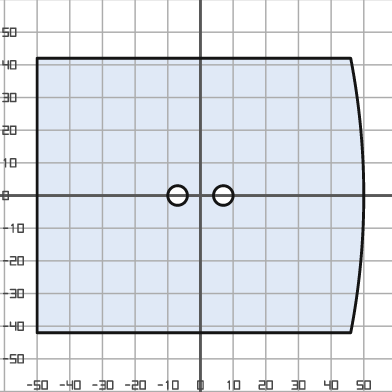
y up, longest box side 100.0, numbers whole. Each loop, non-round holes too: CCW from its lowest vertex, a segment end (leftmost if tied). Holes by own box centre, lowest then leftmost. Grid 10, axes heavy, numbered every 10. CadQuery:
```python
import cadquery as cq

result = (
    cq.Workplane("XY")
    .moveTo(-50.0, -42.0)
    .lineTo(46.0, -42.0)
    .threePointArc((50.0, 0.0), (46.0, 42.0))
    .lineTo(-50.0, 42.0)
    .close()
    .moveTo(-7.0, 0.0)
    .circle(3.0)
    .moveTo(7.0, 0.0)
    .circle(3.0)
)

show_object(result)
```